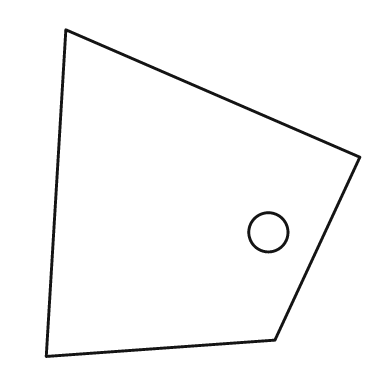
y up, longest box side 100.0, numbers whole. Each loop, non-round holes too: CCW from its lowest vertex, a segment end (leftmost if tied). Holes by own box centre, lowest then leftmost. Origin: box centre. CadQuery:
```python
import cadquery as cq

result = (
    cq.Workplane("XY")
    .moveTo(-48.0, -50.0)
    .lineTo(22.0, -45.0)
    .lineTo(48.0, 11.0)
    .lineTo(-42.0, 50.0)
    .close()
    .moveTo(20.0, -12.0)
    .circle(6.0)
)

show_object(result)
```